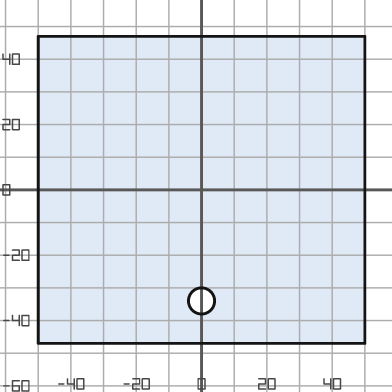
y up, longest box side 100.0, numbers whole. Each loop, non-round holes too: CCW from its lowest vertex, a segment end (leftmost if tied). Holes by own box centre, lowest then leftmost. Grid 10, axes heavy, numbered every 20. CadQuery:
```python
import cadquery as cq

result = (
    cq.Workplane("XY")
    .moveTo(-50.0, -47.0)
    .lineTo(50.0, -47.0)
    .lineTo(50.0, 47.0)
    .lineTo(-50.0, 47.0)
    .close()
    .moveTo(0.0, -34.0)
    .circle(4.0)
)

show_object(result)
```